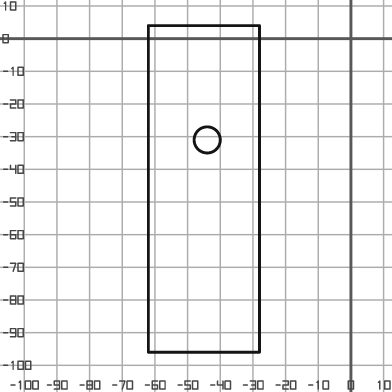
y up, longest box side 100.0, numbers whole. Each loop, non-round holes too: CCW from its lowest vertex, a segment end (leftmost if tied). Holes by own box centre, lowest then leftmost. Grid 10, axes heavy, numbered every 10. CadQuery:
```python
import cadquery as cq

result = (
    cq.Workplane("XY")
    .moveTo(-62.0, -96.0)
    .lineTo(-28.0, -96.0)
    .lineTo(-28.0, 4.0)
    .lineTo(-62.0, 4.0)
    .close()
    .moveTo(-44.0, -31.0)
    .circle(4.0)
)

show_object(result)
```